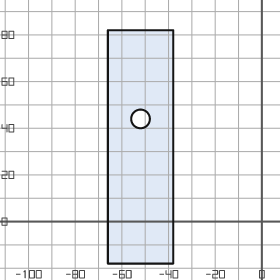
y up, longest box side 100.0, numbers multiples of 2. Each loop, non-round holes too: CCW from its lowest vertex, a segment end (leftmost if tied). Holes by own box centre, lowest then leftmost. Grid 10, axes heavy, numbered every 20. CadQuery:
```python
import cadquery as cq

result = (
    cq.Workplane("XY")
    .moveTo(-66.0, -18.0)
    .lineTo(-38.0, -18.0)
    .lineTo(-38.0, 82.0)
    .lineTo(-66.0, 82.0)
    .close()
    .moveTo(-52.0, 44.0)
    .circle(4.0)
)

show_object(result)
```